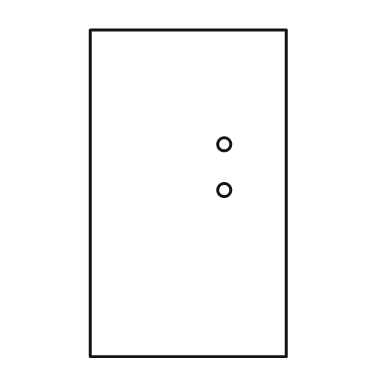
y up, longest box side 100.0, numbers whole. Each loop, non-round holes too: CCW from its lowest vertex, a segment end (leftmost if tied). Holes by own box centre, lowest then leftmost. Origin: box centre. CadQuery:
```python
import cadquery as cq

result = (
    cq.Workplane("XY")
    .moveTo(-30.0, -50.0)
    .lineTo(30.0, -50.0)
    .lineTo(30.0, 50.0)
    .lineTo(-30.0, 50.0)
    .close()
    .moveTo(11.0, 1.0)
    .circle(2.0)
    .moveTo(11.0, 15.0)
    .circle(2.0)
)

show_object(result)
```